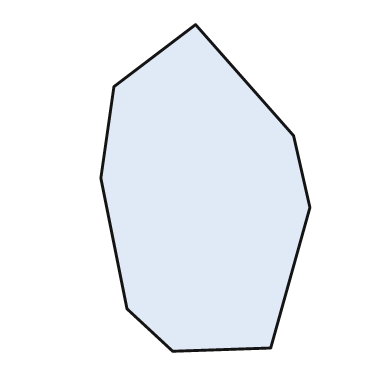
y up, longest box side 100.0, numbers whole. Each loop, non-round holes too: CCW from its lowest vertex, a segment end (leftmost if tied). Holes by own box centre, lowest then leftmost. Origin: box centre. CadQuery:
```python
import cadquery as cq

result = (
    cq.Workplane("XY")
    .moveTo(-10.0, -50.0)
    .lineTo(20.0, -49.0)
    .lineTo(32.0, -6.0)
    .lineTo(27.0, 16.0)
    .lineTo(-3.0, 50.0)
    .lineTo(-28.0, 31.0)
    .lineTo(-32.0, 3.0)
    .lineTo(-24.0, -37.0)
    .close()
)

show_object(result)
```